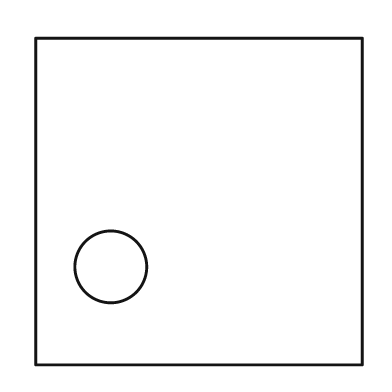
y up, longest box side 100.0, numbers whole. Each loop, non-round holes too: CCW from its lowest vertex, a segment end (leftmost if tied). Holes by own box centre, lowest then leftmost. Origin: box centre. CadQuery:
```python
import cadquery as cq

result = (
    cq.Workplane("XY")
    .moveTo(-50.0, -50.0)
    .lineTo(50.0, -50.0)
    .lineTo(50.0, 50.0)
    .lineTo(-50.0, 50.0)
    .close()
    .moveTo(-27.0, -20.0)
    .circle(11.0)
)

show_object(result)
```